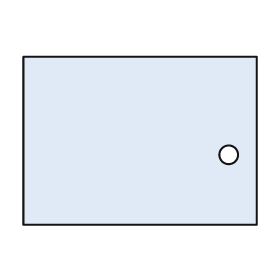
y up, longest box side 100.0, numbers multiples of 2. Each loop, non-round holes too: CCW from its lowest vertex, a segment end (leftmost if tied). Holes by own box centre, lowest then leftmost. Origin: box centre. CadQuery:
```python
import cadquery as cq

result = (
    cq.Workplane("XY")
    .moveTo(-50.0, -36.0)
    .lineTo(50.0, -36.0)
    .lineTo(50.0, 36.0)
    .lineTo(-50.0, 36.0)
    .close()
    .moveTo(38.0, -6.0)
    .circle(4.0)
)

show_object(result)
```